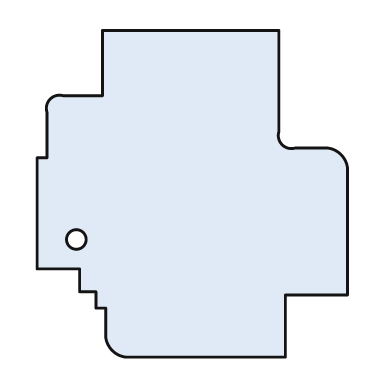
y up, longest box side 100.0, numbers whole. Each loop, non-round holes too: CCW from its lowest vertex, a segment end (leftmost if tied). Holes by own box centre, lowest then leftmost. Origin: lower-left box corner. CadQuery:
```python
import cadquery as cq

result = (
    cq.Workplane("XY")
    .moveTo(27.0, 0.0)
    .lineTo(76.0, 0.0)
    .lineTo(76.0, 19.0)
    .lineTo(95.0, 19.0)
    .lineTo(95.0, 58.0)
    .threePointArc((93.0, 62.0), (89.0, 64.0))
    .lineTo(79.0, 64.0)
    .threePointArc((75.0, 65.0), (74.0, 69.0))
    .lineTo(74.0, 100.0)
    .lineTo(20.0, 100.0)
    .lineTo(20.0, 80.0)
    .lineTo(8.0, 80.0)
    .threePointArc((4.0, 79.0), (3.0, 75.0))
    .lineTo(3.0, 61.0)
    .lineTo(0.0, 61.0)
    .lineTo(0.0, 27.0)
    .lineTo(13.0, 27.0)
    .lineTo(13.0, 20.0)
    .lineTo(18.0, 20.0)
    .lineTo(18.0, 15.0)
    .lineTo(21.0, 15.0)
    .lineTo(21.0, 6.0)
    .threePointArc((23.0, 2.0), (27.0, 0.0))
    .close()
    .moveTo(12.0, 36.0)
    .circle(3.0)
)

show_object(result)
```